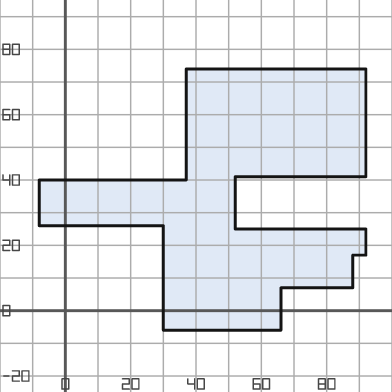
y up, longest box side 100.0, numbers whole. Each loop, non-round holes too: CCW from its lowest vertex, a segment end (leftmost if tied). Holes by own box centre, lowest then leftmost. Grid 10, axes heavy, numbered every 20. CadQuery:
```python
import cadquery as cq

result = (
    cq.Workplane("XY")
    .moveTo(30.0, -6.0)
    .lineTo(66.0, -6.0)
    .lineTo(66.0, 7.0)
    .lineTo(88.0, 7.0)
    .lineTo(88.0, 17.0)
    .lineTo(92.0, 17.0)
    .lineTo(92.0, 25.0)
    .lineTo(52.0, 25.0)
    .lineTo(52.0, 41.0)
    .lineTo(92.0, 41.0)
    .lineTo(92.0, 74.0)
    .lineTo(37.0, 74.0)
    .lineTo(37.0, 40.0)
    .lineTo(-8.0, 40.0)
    .lineTo(-8.0, 26.0)
    .lineTo(30.0, 26.0)
    .close()
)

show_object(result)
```